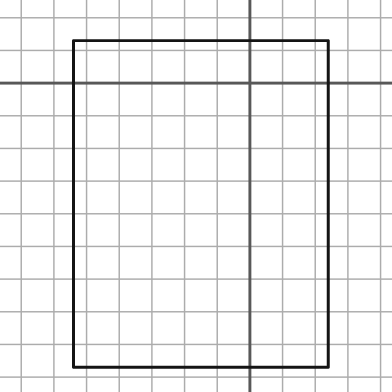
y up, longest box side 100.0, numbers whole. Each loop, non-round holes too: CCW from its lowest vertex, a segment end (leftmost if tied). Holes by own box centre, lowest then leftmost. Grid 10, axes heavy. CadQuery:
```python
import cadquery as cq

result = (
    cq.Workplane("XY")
    .moveTo(-54.0, -87.0)
    .lineTo(24.0, -87.0)
    .lineTo(24.0, 13.0)
    .lineTo(-54.0, 13.0)
    .close()
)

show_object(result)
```